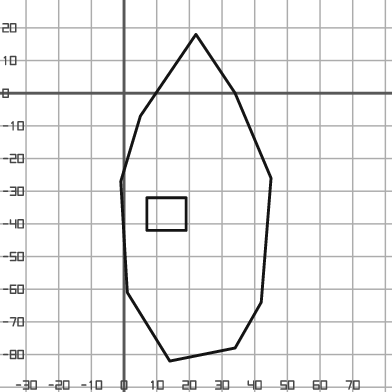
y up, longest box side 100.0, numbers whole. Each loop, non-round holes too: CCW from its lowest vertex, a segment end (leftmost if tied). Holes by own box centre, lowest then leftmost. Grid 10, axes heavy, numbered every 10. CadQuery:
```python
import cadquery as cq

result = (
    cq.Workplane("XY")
    .moveTo(14.0, -82.0)
    .lineTo(34.0, -78.0)
    .lineTo(42.0, -64.0)
    .lineTo(45.0, -26.0)
    .lineTo(34.0, 0.0)
    .lineTo(22.0, 18.0)
    .lineTo(5.0, -7.0)
    .lineTo(-1.0, -27.0)
    .lineTo(1.0, -61.0)
    .close()
    .moveTo(7.0, -42.0)
    .lineTo(19.0, -42.0)
    .lineTo(19.0, -32.0)
    .lineTo(7.0, -32.0)
    .close()
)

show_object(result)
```